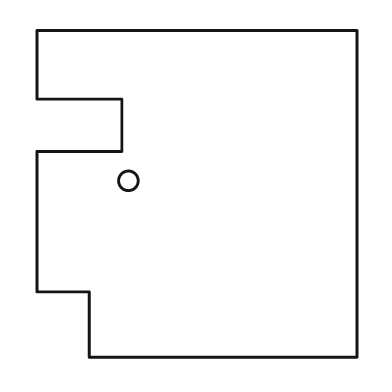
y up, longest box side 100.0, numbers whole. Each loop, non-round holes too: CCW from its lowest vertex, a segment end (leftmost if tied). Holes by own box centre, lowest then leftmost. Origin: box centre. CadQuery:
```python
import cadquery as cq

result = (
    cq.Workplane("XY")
    .moveTo(-33.0, -50.0)
    .lineTo(49.0, -50.0)
    .lineTo(49.0, 50.0)
    .lineTo(-49.0, 50.0)
    .lineTo(-49.0, 29.0)
    .lineTo(-23.0, 29.0)
    .lineTo(-23.0, 13.0)
    .lineTo(-49.0, 13.0)
    .lineTo(-49.0, -30.0)
    .lineTo(-33.0, -30.0)
    .close()
    .moveTo(-21.0, 4.0)
    .circle(3.0)
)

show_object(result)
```